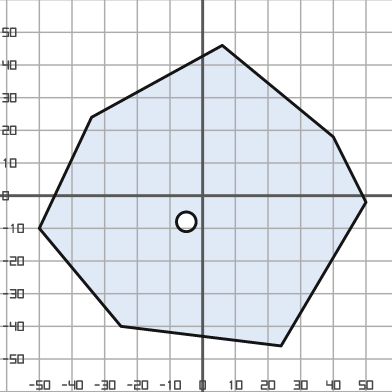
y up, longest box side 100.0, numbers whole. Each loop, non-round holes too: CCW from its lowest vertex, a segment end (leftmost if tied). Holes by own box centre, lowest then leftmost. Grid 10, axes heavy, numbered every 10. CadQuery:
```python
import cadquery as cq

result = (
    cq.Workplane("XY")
    .moveTo(24.0, -46.0)
    .lineTo(50.0, -2.0)
    .lineTo(40.0, 18.0)
    .lineTo(6.0, 46.0)
    .lineTo(-34.0, 24.0)
    .lineTo(-50.0, -10.0)
    .lineTo(-25.0, -40.0)
    .close()
    .moveTo(-5.0, -8.0)
    .circle(3.0)
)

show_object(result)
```